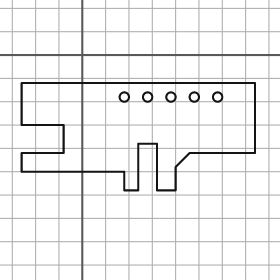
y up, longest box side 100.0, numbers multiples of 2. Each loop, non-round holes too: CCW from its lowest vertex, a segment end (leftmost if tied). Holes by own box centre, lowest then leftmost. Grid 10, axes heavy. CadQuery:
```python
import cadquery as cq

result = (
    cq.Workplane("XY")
    .moveTo(18.0, -58.0)
    .lineTo(24.0, -58.0)
    .lineTo(24.0, -38.0)
    .lineTo(32.0, -38.0)
    .lineTo(32.0, -58.0)
    .lineTo(40.0, -58.0)
    .lineTo(40.0, -48.0)
    .lineTo(46.0, -42.0)
    .lineTo(74.0, -42.0)
    .lineTo(74.0, -12.0)
    .lineTo(-26.0, -12.0)
    .lineTo(-26.0, -30.0)
    .lineTo(-8.0, -30.0)
    .lineTo(-8.0, -42.0)
    .lineTo(-26.0, -42.0)
    .lineTo(-26.0, -50.0)
    .lineTo(18.0, -50.0)
    .close()
    .moveTo(18.0, -18.0)
    .circle(2.0)
    .moveTo(28.0, -18.0)
    .circle(2.0)
    .moveTo(38.0, -18.0)
    .circle(2.0)
    .moveTo(48.0, -18.0)
    .circle(2.0)
    .moveTo(58.0, -18.0)
    .circle(2.0)
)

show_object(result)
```